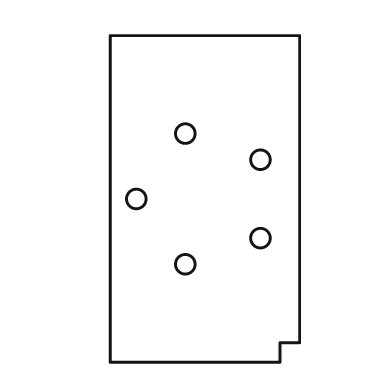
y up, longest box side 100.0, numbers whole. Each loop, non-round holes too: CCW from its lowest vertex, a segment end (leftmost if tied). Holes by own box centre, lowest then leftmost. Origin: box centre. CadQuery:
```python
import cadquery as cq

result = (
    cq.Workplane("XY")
    .moveTo(-29.0, -50.0)
    .lineTo(23.0, -50.0)
    .lineTo(23.0, -44.0)
    .lineTo(29.0, -44.0)
    .lineTo(29.0, 50.0)
    .lineTo(-29.0, 50.0)
    .close()
    .moveTo(-6.0, -20.0)
    .circle(3.0)
    .moveTo(17.0, -12.0)
    .circle(3.0)
    .moveTo(-21.0, 0.0)
    .circle(3.0)
    .moveTo(17.0, 12.0)
    .circle(3.0)
    .moveTo(-6.0, 20.0)
    .circle(3.0)
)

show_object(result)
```